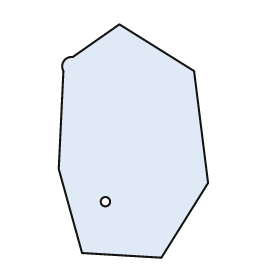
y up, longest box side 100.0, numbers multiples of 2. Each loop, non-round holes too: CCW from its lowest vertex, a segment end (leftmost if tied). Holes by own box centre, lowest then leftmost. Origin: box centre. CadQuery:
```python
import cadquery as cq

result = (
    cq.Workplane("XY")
    .moveTo(12.0, -50.0)
    .lineTo(32.0, -18.0)
    .lineTo(26.0, 30.0)
    .lineTo(-6.0, 50.0)
    .lineTo(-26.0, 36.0)
    .threePointArc((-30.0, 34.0), (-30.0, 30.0))
    .lineTo(-32.0, -12.0)
    .lineTo(-22.0, -48.0)
    .close()
    .moveTo(-12.0, -26.0)
    .circle(2.0)
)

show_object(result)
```